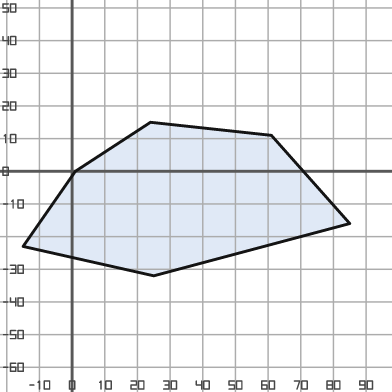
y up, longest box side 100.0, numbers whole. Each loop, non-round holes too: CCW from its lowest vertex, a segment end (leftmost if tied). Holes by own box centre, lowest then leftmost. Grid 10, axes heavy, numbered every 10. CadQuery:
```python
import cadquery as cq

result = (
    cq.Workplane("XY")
    .moveTo(25.0, -32.0)
    .lineTo(85.0, -16.0)
    .lineTo(61.0, 11.0)
    .lineTo(24.0, 15.0)
    .lineTo(1.0, 0.0)
    .lineTo(-15.0, -23.0)
    .close()
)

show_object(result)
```